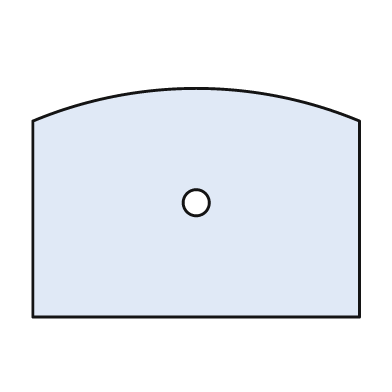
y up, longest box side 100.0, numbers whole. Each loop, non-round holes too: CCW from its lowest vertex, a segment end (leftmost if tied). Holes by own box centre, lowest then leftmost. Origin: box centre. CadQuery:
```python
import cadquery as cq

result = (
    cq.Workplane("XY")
    .moveTo(-50.0, -35.0)
    .lineTo(50.0, -35.0)
    .lineTo(50.0, 25.0)
    .threePointArc((0.0, 35.0), (-50.0, 25.0))
    .close()
    .moveTo(0.0, 0.0)
    .circle(4.0)
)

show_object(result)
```